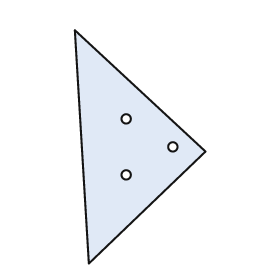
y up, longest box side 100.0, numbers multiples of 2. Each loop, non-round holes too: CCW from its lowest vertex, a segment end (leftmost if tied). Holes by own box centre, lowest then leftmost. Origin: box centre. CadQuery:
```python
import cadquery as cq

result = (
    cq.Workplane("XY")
    .moveTo(-22.0, -50.0)
    .lineTo(28.0, -2.0)
    .lineTo(-28.0, 50.0)
    .close()
    .moveTo(-6.0, -12.0)
    .circle(2.0)
    .moveTo(14.0, 0.0)
    .circle(2.0)
    .moveTo(-6.0, 12.0)
    .circle(2.0)
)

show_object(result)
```